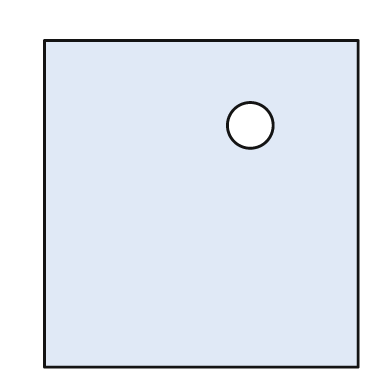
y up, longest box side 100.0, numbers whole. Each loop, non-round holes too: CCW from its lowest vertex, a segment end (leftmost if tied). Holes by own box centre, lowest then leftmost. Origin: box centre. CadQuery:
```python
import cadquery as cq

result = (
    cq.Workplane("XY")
    .moveTo(-48.0, -50.0)
    .lineTo(48.0, -50.0)
    .lineTo(48.0, 50.0)
    .lineTo(-48.0, 50.0)
    .close()
    .moveTo(15.0, 24.0)
    .circle(7.0)
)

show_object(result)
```